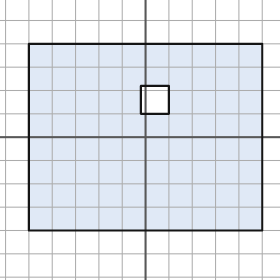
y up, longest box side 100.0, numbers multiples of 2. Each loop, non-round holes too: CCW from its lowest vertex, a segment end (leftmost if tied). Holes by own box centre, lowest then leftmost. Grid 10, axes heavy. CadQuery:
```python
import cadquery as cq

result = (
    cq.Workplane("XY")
    .moveTo(-50.0, -40.0)
    .lineTo(50.0, -40.0)
    .lineTo(50.0, 40.0)
    .lineTo(-50.0, 40.0)
    .close()
    .moveTo(-2.0, 10.0)
    .lineTo(10.0, 10.0)
    .lineTo(10.0, 22.0)
    .lineTo(-2.0, 22.0)
    .close()
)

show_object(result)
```